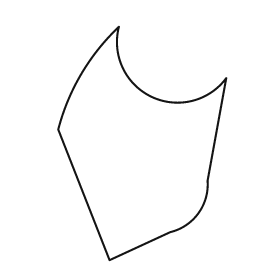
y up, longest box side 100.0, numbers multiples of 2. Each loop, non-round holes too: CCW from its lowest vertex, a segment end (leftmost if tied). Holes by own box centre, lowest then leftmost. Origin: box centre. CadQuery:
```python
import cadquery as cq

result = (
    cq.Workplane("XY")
    .moveTo(-14.0, -50.0)
    .lineTo(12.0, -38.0)
    .threePointArc((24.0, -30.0), (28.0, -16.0))
    .lineTo(36.0, 28.0)
    .threePointArc((4.0, 20.0), (-10.0, 50.0))
    .threePointArc((-26.0, 30.0), (-36.0, 6.0))
    .close()
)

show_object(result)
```